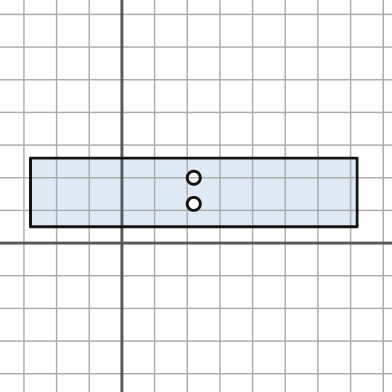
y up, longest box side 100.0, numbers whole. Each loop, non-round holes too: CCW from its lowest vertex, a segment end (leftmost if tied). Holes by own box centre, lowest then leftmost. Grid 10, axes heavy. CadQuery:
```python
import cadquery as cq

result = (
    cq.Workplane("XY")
    .moveTo(-28.0, 5.0)
    .lineTo(72.0, 5.0)
    .lineTo(72.0, 26.0)
    .lineTo(-28.0, 26.0)
    .close()
    .moveTo(22.0, 12.0)
    .circle(2.0)
    .moveTo(22.0, 20.0)
    .circle(2.0)
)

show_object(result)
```